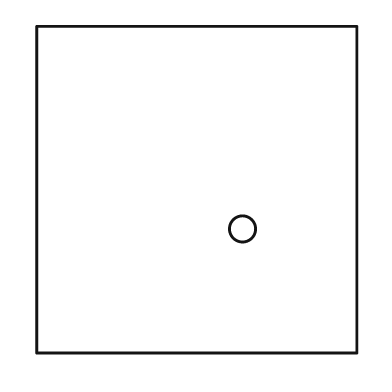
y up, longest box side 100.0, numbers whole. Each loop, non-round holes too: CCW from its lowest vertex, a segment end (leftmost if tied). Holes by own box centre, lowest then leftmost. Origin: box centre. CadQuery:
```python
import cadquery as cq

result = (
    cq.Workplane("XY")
    .moveTo(-49.0, -50.0)
    .lineTo(49.0, -50.0)
    .lineTo(49.0, 50.0)
    .lineTo(-49.0, 50.0)
    .close()
    .moveTo(14.0, -12.0)
    .circle(4.0)
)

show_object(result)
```